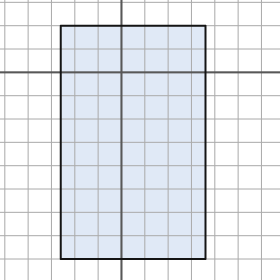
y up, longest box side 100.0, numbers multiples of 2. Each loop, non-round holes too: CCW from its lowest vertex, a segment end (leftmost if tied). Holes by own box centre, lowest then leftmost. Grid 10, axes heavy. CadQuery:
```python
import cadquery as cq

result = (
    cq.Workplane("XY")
    .moveTo(-26.0, -80.0)
    .lineTo(36.0, -80.0)
    .lineTo(36.0, 20.0)
    .lineTo(-26.0, 20.0)
    .close()
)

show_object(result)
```